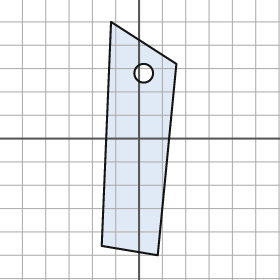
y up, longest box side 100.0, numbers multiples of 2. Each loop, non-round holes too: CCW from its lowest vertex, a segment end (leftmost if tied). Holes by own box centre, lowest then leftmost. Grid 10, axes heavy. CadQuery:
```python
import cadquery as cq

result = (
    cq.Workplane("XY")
    .moveTo(8.0, -50.0)
    .lineTo(16.0, 32.0)
    .lineTo(-12.0, 50.0)
    .lineTo(-16.0, -46.0)
    .close()
    .moveTo(2.0, 28.0)
    .circle(4.0)
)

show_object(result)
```